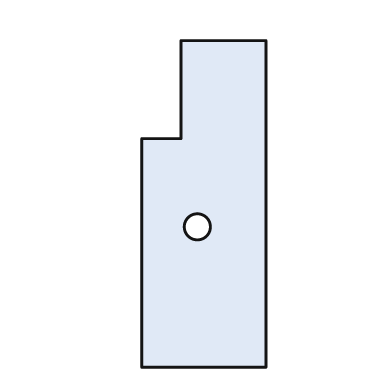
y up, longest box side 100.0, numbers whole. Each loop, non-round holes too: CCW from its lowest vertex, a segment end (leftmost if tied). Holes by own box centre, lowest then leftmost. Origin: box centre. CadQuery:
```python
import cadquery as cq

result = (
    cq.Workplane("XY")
    .moveTo(-19.0, -50.0)
    .lineTo(19.0, -50.0)
    .lineTo(19.0, 50.0)
    .lineTo(-7.0, 50.0)
    .lineTo(-7.0, 20.0)
    .lineTo(-19.0, 20.0)
    .close()
    .moveTo(-2.0, -7.0)
    .circle(4.0)
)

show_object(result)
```